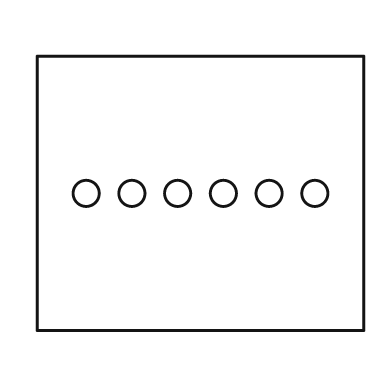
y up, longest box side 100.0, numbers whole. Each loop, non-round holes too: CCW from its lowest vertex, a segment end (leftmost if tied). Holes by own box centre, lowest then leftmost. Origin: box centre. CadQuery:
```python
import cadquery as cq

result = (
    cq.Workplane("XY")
    .moveTo(-50.0, -42.0)
    .lineTo(50.0, -42.0)
    .lineTo(50.0, 42.0)
    .lineTo(-50.0, 42.0)
    .close()
    .moveTo(-35.0, 0.0)
    .circle(4.0)
    .moveTo(-21.0, 0.0)
    .circle(4.0)
    .moveTo(-7.0, 0.0)
    .circle(4.0)
    .moveTo(7.0, 0.0)
    .circle(4.0)
    .moveTo(21.0, 0.0)
    .circle(4.0)
    .moveTo(35.0, 0.0)
    .circle(4.0)
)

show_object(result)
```